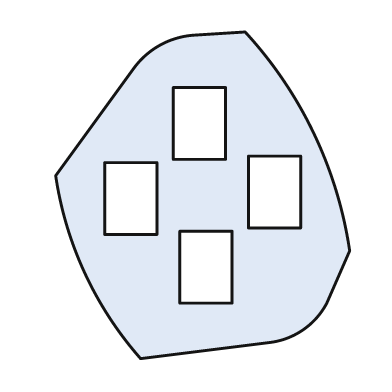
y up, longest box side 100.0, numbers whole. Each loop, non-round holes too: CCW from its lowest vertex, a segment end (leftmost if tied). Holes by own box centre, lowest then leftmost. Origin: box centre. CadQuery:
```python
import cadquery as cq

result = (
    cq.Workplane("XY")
    .moveTo(-19.0, -50.0)
    .lineTo(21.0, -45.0)
    .threePointArc((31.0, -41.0), (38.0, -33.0))
    .lineTo(45.0, -17.0)
    .threePointArc((34.0, 19.0), (13.0, 50.0))
    .lineTo(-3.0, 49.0)
    .threePointArc((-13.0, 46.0), (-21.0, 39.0))
    .lineTo(-45.0, 6.0)
    .threePointArc((-36.0, -24.0), (-19.0, -50.0))
    .close()
    .moveTo(-7.0, -33.0)
    .lineTo(9.0, -33.0)
    .lineTo(9.0, -11.0)
    .lineTo(-7.0, -11.0)
    .close()
    .moveTo(-30.0, -12.0)
    .lineTo(-14.0, -12.0)
    .lineTo(-14.0, 10.0)
    .lineTo(-30.0, 10.0)
    .close()
    .moveTo(14.0, -10.0)
    .lineTo(30.0, -10.0)
    .lineTo(30.0, 12.0)
    .lineTo(14.0, 12.0)
    .close()
    .moveTo(-9.0, 11.0)
    .lineTo(7.0, 11.0)
    .lineTo(7.0, 33.0)
    .lineTo(-9.0, 33.0)
    .close()
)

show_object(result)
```